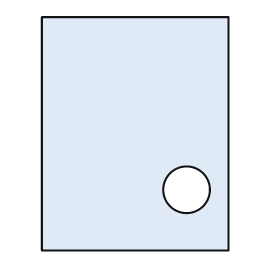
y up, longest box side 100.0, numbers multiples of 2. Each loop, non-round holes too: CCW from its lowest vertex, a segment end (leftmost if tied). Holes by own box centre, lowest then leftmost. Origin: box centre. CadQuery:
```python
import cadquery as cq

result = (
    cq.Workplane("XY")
    .moveTo(-40.0, -50.0)
    .lineTo(40.0, -50.0)
    .lineTo(40.0, 50.0)
    .lineTo(-40.0, 50.0)
    .close()
    .moveTo(22.0, -24.0)
    .circle(10.0)
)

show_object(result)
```